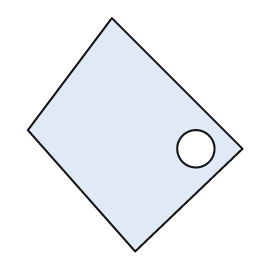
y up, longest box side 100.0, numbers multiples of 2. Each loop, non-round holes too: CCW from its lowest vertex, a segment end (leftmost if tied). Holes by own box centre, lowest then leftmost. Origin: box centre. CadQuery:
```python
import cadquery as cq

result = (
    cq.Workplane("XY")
    .moveTo(0.0, -50.0)
    .lineTo(46.0, -6.0)
    .lineTo(-10.0, 50.0)
    .lineTo(-46.0, 2.0)
    .close()
    .moveTo(26.0, -6.0)
    .circle(8.0)
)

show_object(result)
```